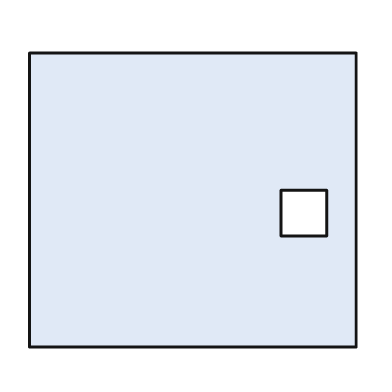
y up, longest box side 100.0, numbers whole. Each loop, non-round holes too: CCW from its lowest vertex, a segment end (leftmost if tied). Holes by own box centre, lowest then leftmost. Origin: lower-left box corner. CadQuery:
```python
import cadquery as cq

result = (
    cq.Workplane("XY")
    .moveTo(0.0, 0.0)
    .lineTo(100.0, 0.0)
    .lineTo(100.0, 90.0)
    .lineTo(0.0, 90.0)
    .close()
    .moveTo(77.0, 34.0)
    .lineTo(91.0, 34.0)
    .lineTo(91.0, 48.0)
    .lineTo(77.0, 48.0)
    .close()
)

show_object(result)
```